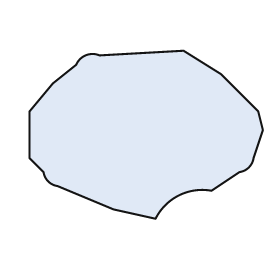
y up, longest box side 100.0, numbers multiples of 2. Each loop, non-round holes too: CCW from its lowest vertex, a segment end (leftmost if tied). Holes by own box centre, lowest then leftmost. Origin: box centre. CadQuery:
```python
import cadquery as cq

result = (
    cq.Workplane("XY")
    .moveTo(4.0, -36.0)
    .threePointArc((14.0, -26.0), (28.0, -24.0))
    .lineTo(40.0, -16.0)
    .threePointArc((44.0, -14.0), (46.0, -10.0))
    .lineTo(50.0, 2.0)
    .lineTo(48.0, 10.0)
    .lineTo(32.0, 26.0)
    .lineTo(16.0, 36.0)
    .lineTo(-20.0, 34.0)
    .threePointArc((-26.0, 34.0), (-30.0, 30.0))
    .lineTo(-40.0, 22.0)
    .lineTo(-50.0, 10.0)
    .lineTo(-50.0, -10.0)
    .lineTo(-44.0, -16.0)
    .threePointArc((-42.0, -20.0), (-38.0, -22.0))
    .lineTo(-14.0, -32.0)
    .close()
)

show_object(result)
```